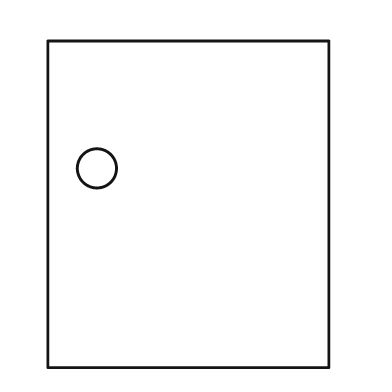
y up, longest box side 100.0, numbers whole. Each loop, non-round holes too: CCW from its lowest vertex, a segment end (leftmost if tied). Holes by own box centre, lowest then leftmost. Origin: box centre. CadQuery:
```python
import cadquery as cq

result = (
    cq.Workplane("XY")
    .moveTo(-43.0, -50.0)
    .lineTo(43.0, -50.0)
    .lineTo(43.0, 50.0)
    .lineTo(-43.0, 50.0)
    .close()
    .moveTo(-28.0, 11.0)
    .circle(6.0)
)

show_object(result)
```